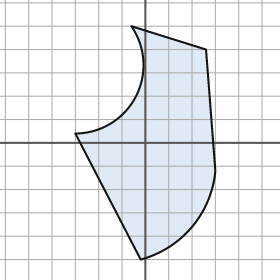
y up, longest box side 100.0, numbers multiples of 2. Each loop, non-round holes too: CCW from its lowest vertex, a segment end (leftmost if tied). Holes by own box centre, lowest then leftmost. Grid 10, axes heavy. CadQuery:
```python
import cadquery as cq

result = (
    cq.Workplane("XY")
    .moveTo(-2.0, -50.0)
    .threePointArc((20.0, -36.0), (30.0, -12.0))
    .lineTo(26.0, 40.0)
    .lineTo(-6.0, 50.0)
    .threePointArc((-4.0, 20.0), (-30.0, 4.0))
    .close()
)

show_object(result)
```